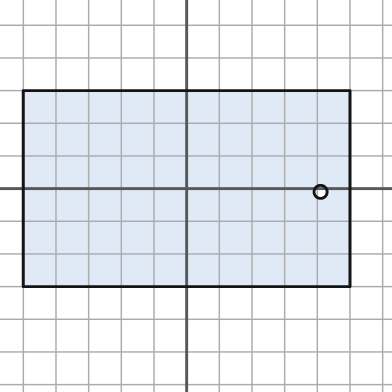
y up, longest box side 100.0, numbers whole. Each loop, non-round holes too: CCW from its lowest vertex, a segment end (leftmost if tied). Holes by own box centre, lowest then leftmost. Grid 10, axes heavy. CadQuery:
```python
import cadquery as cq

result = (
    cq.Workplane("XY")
    .moveTo(-50.0, -30.0)
    .lineTo(50.0, -30.0)
    .lineTo(50.0, 30.0)
    .lineTo(-50.0, 30.0)
    .close()
    .moveTo(41.0, -1.0)
    .circle(2.0)
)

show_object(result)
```